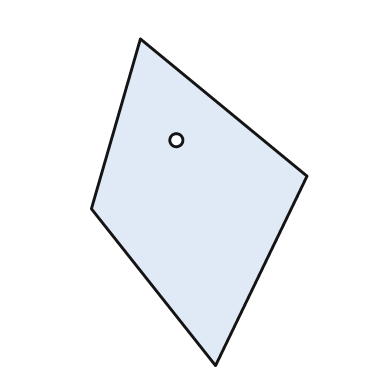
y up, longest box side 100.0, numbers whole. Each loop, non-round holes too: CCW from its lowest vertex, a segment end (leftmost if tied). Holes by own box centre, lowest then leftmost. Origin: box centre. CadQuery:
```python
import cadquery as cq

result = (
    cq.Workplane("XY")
    .moveTo(5.0, -50.0)
    .lineTo(33.0, 8.0)
    .lineTo(-18.0, 50.0)
    .lineTo(-33.0, -2.0)
    .close()
    .moveTo(-7.0, 19.0)
    .circle(2.0)
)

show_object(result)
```